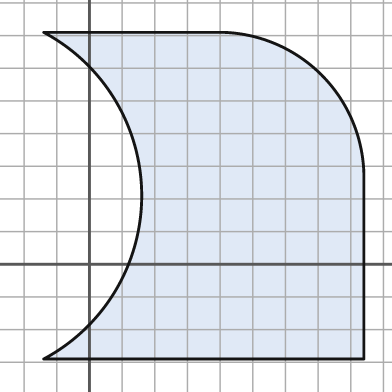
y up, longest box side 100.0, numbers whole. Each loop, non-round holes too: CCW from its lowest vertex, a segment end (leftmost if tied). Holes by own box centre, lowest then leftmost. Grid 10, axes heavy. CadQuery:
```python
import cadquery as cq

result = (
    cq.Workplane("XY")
    .moveTo(-14.0, -29.0)
    .lineTo(84.0, -29.0)
    .lineTo(84.0, 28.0)
    .threePointArc((71.0, 58.0), (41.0, 71.0))
    .lineTo(-14.0, 71.0)
    .threePointArc((16.0, 21.0), (-14.0, -29.0))
    .close()
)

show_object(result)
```